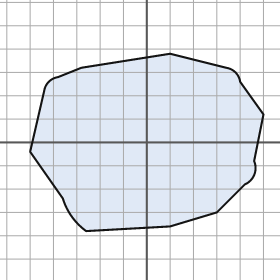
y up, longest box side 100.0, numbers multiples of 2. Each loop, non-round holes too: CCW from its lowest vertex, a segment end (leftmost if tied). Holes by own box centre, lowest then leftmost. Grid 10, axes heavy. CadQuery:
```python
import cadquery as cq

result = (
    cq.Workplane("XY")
    .moveTo(-26.0, -38.0)
    .lineTo(10.0, -36.0)
    .lineTo(30.0, -30.0)
    .lineTo(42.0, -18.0)
    .threePointArc((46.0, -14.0), (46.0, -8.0))
    .lineTo(50.0, 12.0)
    .lineTo(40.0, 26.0)
    .threePointArc((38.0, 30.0), (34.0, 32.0))
    .lineTo(10.0, 38.0)
    .lineTo(-28.0, 32.0)
    .lineTo(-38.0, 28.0)
    .threePointArc((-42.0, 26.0), (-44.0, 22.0))
    .lineTo(-50.0, -4.0)
    .lineTo(-36.0, -24.0)
    .threePointArc((-32.0, -32.0), (-26.0, -38.0))
    .close()
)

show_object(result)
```